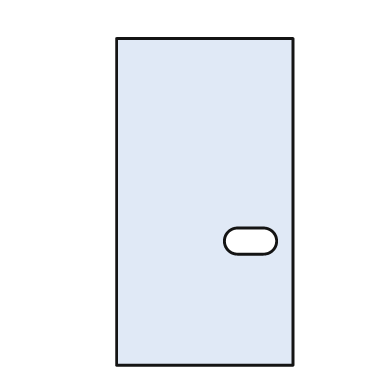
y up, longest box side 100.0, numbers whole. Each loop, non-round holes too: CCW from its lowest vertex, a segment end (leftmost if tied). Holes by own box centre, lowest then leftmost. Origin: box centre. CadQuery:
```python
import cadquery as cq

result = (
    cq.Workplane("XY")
    .moveTo(-27.0, -50.0)
    .lineTo(27.0, -50.0)
    .lineTo(27.0, 50.0)
    .lineTo(-27.0, 50.0)
    .close()
    .moveTo(10.0, -16.0)
    .lineTo(18.0, -16.0)
    .threePointArc((22.0, -12.0), (18.0, -8.0))
    .lineTo(10.0, -8.0)
    .threePointArc((6.0, -12.0), (10.0, -16.0))
    .close()
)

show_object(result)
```